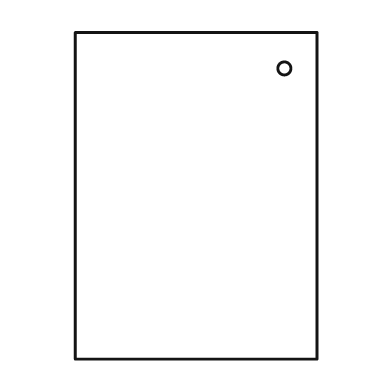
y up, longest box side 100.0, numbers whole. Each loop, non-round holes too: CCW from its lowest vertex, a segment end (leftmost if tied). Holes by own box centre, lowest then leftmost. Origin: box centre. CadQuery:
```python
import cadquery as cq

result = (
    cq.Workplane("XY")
    .moveTo(-37.0, -50.0)
    .lineTo(37.0, -50.0)
    .lineTo(37.0, 50.0)
    .lineTo(-37.0, 50.0)
    .close()
    .moveTo(27.0, 39.0)
    .circle(2.0)
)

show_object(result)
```